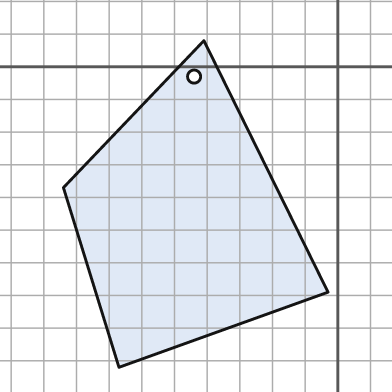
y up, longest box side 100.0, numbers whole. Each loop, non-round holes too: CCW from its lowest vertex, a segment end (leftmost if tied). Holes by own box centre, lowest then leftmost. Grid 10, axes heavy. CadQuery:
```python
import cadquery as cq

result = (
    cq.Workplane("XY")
    .moveTo(-67.0, -92.0)
    .lineTo(-3.0, -69.0)
    .lineTo(-41.0, 8.0)
    .lineTo(-84.0, -37.0)
    .close()
    .moveTo(-44.0, -3.0)
    .circle(2.0)
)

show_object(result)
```